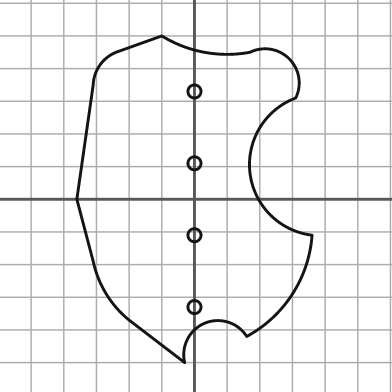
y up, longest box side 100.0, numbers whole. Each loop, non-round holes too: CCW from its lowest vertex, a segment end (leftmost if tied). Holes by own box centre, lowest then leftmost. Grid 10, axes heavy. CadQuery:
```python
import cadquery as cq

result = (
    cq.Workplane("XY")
    .moveTo(-3.0, -50.0)
    .threePointArc((3.0, -38.0), (16.0, -42.0))
    .threePointArc((30.0, -29.0), (36.0, -11.0))
    .threePointArc((17.0, 8.0), (31.0, 31.0))
    .threePointArc((29.0, 43.0), (17.0, 45.0))
    .threePointArc((3.0, 45.0), (-10.0, 50.0))
    .lineTo(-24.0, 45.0)
    .threePointArc((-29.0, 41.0), (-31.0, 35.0))
    .lineTo(-36.0, 0.0)
    .lineTo(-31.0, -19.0)
    .threePointArc((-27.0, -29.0), (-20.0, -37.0))
    .close()
    .moveTo(0.0, -33.0)
    .circle(2.0)
    .moveTo(0.0, -11.0)
    .circle(2.0)
    .moveTo(0.0, 11.0)
    .circle(2.0)
    .moveTo(0.0, 33.0)
    .circle(2.0)
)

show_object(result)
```